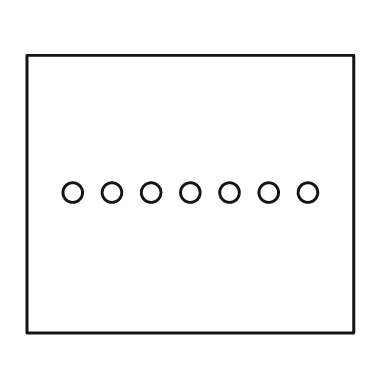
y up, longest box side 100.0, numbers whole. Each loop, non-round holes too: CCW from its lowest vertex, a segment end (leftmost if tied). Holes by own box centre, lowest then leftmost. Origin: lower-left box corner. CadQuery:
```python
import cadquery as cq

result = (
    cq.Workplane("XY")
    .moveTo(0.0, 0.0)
    .lineTo(100.0, 0.0)
    .lineTo(100.0, 85.0)
    .lineTo(0.0, 85.0)
    .close()
    .moveTo(14.0, 43.0)
    .circle(3.0)
    .moveTo(26.0, 43.0)
    .circle(3.0)
    .moveTo(38.0, 43.0)
    .circle(3.0)
    .moveTo(50.0, 43.0)
    .circle(3.0)
    .moveTo(62.0, 43.0)
    .circle(3.0)
    .moveTo(74.0, 43.0)
    .circle(3.0)
    .moveTo(86.0, 43.0)
    .circle(3.0)
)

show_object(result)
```